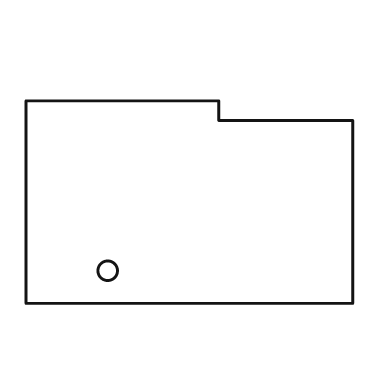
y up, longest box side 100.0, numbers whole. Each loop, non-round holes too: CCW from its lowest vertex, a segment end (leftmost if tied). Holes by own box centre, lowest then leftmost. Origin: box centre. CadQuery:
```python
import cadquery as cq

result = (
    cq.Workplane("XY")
    .moveTo(-50.0, -31.0)
    .lineTo(50.0, -31.0)
    .lineTo(50.0, 25.0)
    .lineTo(9.0, 25.0)
    .lineTo(9.0, 31.0)
    .lineTo(-50.0, 31.0)
    .close()
    .moveTo(-25.0, -21.0)
    .circle(3.0)
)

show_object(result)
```